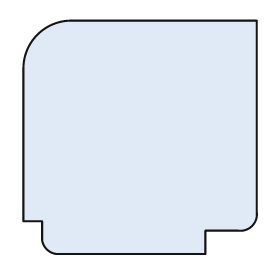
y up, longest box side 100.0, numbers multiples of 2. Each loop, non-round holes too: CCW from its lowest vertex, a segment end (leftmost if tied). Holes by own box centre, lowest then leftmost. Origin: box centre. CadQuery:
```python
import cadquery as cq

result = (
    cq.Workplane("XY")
    .moveTo(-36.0, -50.0)
    .lineTo(28.0, -50.0)
    .lineTo(28.0, -40.0)
    .lineTo(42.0, -40.0)
    .threePointArc((48.0, -38.0), (50.0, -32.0))
    .lineTo(50.0, 50.0)
    .lineTo(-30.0, 50.0)
    .threePointArc((-44.0, 44.0), (-50.0, 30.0))
    .lineTo(-50.0, -36.0)
    .lineTo(-42.0, -36.0)
    .lineTo(-42.0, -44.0)
    .threePointArc((-40.0, -48.0), (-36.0, -50.0))
    .close()
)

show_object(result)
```